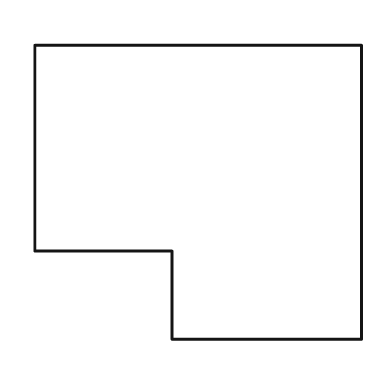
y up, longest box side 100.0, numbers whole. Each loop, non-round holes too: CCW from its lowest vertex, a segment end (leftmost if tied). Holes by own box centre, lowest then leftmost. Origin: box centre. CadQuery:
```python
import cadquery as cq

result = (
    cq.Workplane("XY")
    .moveTo(-8.0, -45.0)
    .lineTo(50.0, -45.0)
    .lineTo(50.0, 45.0)
    .lineTo(-50.0, 45.0)
    .lineTo(-50.0, -18.0)
    .lineTo(-8.0, -18.0)
    .close()
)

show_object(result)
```